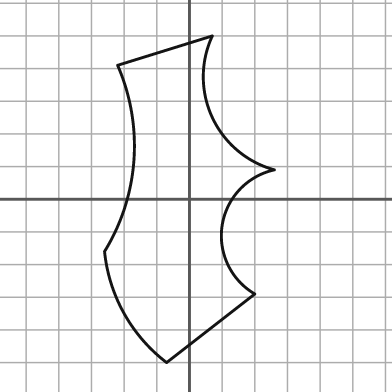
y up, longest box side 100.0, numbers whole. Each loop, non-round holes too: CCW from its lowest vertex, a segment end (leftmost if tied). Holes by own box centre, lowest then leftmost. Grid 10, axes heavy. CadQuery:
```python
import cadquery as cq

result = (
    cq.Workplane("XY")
    .moveTo(-7.0, -50.0)
    .lineTo(20.0, -29.0)
    .threePointArc((10.0, -8.0), (26.0, 9.0))
    .threePointArc((7.0, 25.0), (7.0, 50.0))
    .lineTo(-22.0, 41.0)
    .threePointArc((-17.0, 12.0), (-26.0, -16.0))
    .threePointArc((-20.0, -35.0), (-7.0, -50.0))
    .close()
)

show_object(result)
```